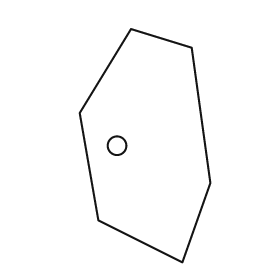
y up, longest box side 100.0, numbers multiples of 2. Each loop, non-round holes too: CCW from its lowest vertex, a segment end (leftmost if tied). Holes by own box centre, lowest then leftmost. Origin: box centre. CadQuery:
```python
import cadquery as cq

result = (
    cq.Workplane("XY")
    .moveTo(16.0, -50.0)
    .lineTo(28.0, -16.0)
    .lineTo(20.0, 42.0)
    .lineTo(-6.0, 50.0)
    .lineTo(-28.0, 14.0)
    .lineTo(-20.0, -32.0)
    .close()
    .moveTo(-12.0, 0.0)
    .circle(4.0)
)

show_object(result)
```